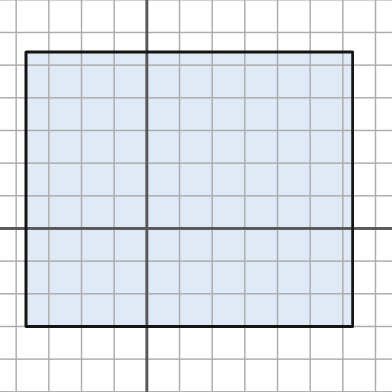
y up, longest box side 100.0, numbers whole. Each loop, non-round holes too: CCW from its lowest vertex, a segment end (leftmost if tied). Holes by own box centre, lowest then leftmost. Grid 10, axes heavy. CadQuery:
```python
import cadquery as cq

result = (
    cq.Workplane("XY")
    .moveTo(-37.0, -30.0)
    .lineTo(63.0, -30.0)
    .lineTo(63.0, 54.0)
    .lineTo(-37.0, 54.0)
    .close()
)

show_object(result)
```